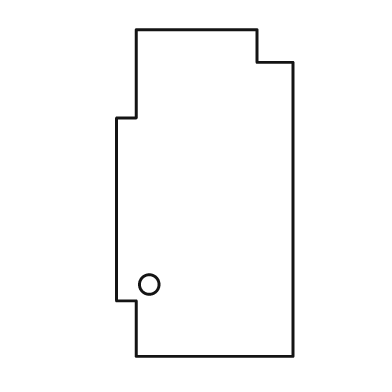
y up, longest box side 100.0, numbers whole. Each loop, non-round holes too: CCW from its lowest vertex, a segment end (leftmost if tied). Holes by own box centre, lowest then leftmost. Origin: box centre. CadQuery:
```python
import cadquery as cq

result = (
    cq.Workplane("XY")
    .moveTo(-21.0, -50.0)
    .lineTo(27.0, -50.0)
    .lineTo(27.0, 40.0)
    .lineTo(16.0, 40.0)
    .lineTo(16.0, 50.0)
    .lineTo(-21.0, 50.0)
    .lineTo(-21.0, 23.0)
    .lineTo(-27.0, 23.0)
    .lineTo(-27.0, -33.0)
    .lineTo(-21.0, -33.0)
    .close()
    .moveTo(-17.0, -28.0)
    .circle(3.0)
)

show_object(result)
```